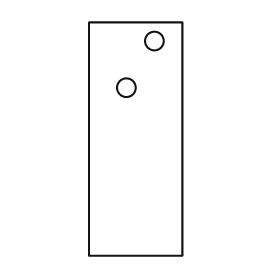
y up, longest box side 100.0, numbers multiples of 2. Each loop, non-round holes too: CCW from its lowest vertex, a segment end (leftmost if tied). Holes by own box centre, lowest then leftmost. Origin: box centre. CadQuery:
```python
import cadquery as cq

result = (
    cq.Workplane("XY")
    .moveTo(-20.0, -50.0)
    .lineTo(20.0, -50.0)
    .lineTo(20.0, 50.0)
    .lineTo(-20.0, 50.0)
    .close()
    .moveTo(-4.0, 22.0)
    .circle(4.0)
    .moveTo(8.0, 42.0)
    .circle(4.0)
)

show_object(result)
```